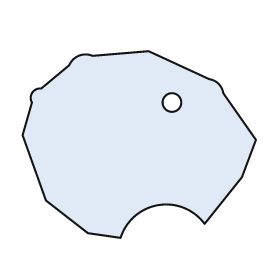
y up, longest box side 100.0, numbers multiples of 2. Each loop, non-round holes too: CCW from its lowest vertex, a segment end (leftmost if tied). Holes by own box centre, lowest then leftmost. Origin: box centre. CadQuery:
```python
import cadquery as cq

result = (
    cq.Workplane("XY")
    .moveTo(-8.0, -40.0)
    .threePointArc((8.0, -26.0), (28.0, -34.0))
    .lineTo(44.0, -14.0)
    .lineTo(50.0, 2.0)
    .lineTo(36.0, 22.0)
    .threePointArc((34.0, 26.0), (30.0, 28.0))
    .lineTo(4.0, 40.0)
    .lineTo(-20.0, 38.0)
    .threePointArc((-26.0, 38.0), (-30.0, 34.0))
    .lineTo(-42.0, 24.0)
    .threePointArc((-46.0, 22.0), (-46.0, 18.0))
    .lineTo(-50.0, 4.0)
    .lineTo(-40.0, -24.0)
    .lineTo(-22.0, -38.0)
    .close()
    .moveTo(14.0, 18.0)
    .circle(4.0)
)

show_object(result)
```